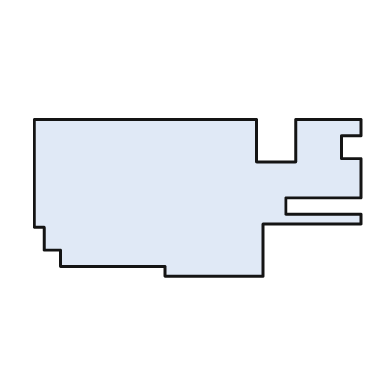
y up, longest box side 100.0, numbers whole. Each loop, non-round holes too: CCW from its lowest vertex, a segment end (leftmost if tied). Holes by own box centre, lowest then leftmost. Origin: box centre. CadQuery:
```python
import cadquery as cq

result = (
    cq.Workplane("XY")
    .moveTo(-10.0, -24.0)
    .lineTo(20.0, -24.0)
    .lineTo(20.0, -8.0)
    .lineTo(50.0, -8.0)
    .lineTo(50.0, -5.0)
    .lineTo(27.0, -5.0)
    .lineTo(27.0, 0.0)
    .lineTo(50.0, 0.0)
    .lineTo(50.0, 12.0)
    .lineTo(44.0, 12.0)
    .lineTo(44.0, 19.0)
    .lineTo(50.0, 19.0)
    .lineTo(50.0, 24.0)
    .lineTo(30.0, 24.0)
    .lineTo(30.0, 11.0)
    .lineTo(18.0, 11.0)
    .lineTo(18.0, 24.0)
    .lineTo(-50.0, 24.0)
    .lineTo(-50.0, -9.0)
    .lineTo(-47.0, -9.0)
    .lineTo(-47.0, -16.0)
    .lineTo(-42.0, -16.0)
    .lineTo(-42.0, -21.0)
    .lineTo(-10.0, -21.0)
    .close()
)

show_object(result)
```